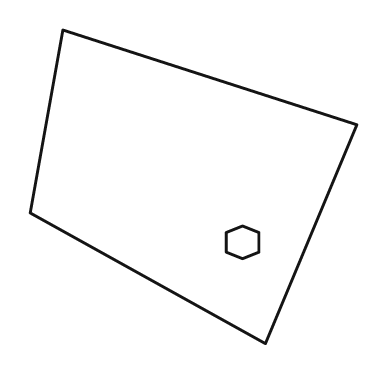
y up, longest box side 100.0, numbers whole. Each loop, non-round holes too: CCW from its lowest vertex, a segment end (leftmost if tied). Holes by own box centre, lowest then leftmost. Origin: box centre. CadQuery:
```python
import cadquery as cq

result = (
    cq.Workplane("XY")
    .moveTo(22.0, -48.0)
    .lineTo(50.0, 19.0)
    .lineTo(-40.0, 48.0)
    .lineTo(-50.0, -8.0)
    .close()
    .moveTo(15.0, -22.0)
    .lineTo(20.0, -20.0)
    .lineTo(20.0, -14.0)
    .lineTo(15.0, -12.0)
    .lineTo(10.0, -14.0)
    .lineTo(10.0, -20.0)
    .close()
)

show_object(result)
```